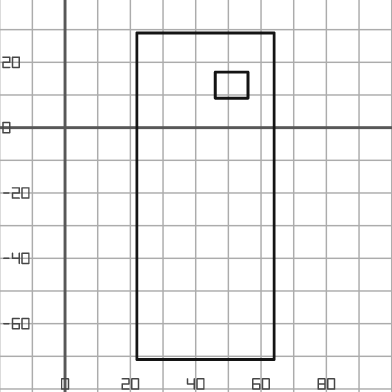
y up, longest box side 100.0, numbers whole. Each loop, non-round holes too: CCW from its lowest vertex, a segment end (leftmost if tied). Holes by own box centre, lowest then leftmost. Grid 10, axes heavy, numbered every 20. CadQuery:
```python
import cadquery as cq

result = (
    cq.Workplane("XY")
    .moveTo(22.0, -71.0)
    .lineTo(64.0, -71.0)
    .lineTo(64.0, 29.0)
    .lineTo(22.0, 29.0)
    .close()
    .moveTo(46.0, 9.0)
    .lineTo(56.0, 9.0)
    .lineTo(56.0, 17.0)
    .lineTo(46.0, 17.0)
    .close()
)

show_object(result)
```